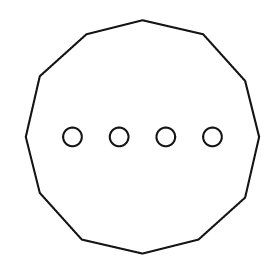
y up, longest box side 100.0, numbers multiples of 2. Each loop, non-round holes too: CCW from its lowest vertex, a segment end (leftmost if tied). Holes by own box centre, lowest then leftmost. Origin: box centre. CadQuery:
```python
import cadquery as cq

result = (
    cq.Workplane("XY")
    .moveTo(0.0, -50.0)
    .lineTo(24.0, -44.0)
    .lineTo(44.0, -26.0)
    .lineTo(50.0, 0.0)
    .lineTo(44.0, 24.0)
    .lineTo(26.0, 44.0)
    .lineTo(0.0, 50.0)
    .lineTo(-24.0, 44.0)
    .lineTo(-44.0, 26.0)
    .lineTo(-50.0, 0.0)
    .lineTo(-44.0, -24.0)
    .lineTo(-26.0, -44.0)
    .close()
    .moveTo(-30.0, 0.0)
    .circle(4.0)
    .moveTo(-10.0, 0.0)
    .circle(4.0)
    .moveTo(10.0, 0.0)
    .circle(4.0)
    .moveTo(30.0, 0.0)
    .circle(4.0)
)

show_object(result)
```